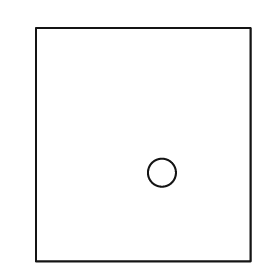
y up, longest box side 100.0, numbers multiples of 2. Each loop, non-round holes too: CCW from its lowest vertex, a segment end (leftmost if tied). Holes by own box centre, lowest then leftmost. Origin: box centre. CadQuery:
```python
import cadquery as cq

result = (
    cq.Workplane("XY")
    .moveTo(-46.0, -50.0)
    .lineTo(46.0, -50.0)
    .lineTo(46.0, 50.0)
    .lineTo(-46.0, 50.0)
    .close()
    .moveTo(8.0, -12.0)
    .circle(6.0)
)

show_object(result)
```